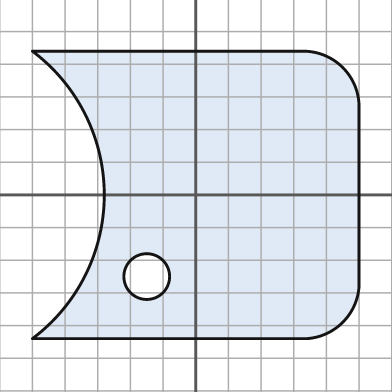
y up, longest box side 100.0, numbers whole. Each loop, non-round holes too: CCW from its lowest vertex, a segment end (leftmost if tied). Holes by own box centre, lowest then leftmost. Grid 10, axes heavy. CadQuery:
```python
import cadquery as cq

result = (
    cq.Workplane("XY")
    .moveTo(-50.0, -44.0)
    .lineTo(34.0, -44.0)
    .threePointArc((45.0, -39.0), (50.0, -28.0))
    .lineTo(50.0, 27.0)
    .threePointArc((45.0, 39.0), (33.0, 44.0))
    .lineTo(-50.0, 44.0)
    .threePointArc((-28.0, 0.0), (-50.0, -44.0))
    .close()
    .moveTo(-15.0, -25.0)
    .circle(7.0)
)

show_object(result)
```